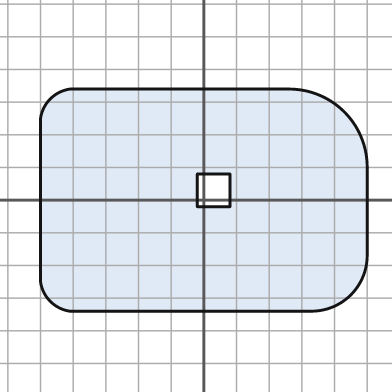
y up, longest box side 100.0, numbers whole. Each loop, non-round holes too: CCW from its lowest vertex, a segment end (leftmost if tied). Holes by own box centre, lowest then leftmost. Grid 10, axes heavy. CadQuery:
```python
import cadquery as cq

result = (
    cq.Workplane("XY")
    .moveTo(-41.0, -34.0)
    .lineTo(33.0, -34.0)
    .threePointArc((45.0, -29.0), (50.0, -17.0))
    .lineTo(50.0, 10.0)
    .threePointArc((43.0, 27.0), (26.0, 34.0))
    .lineTo(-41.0, 34.0)
    .threePointArc((-47.0, 31.0), (-50.0, 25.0))
    .lineTo(-50.0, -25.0)
    .threePointArc((-47.0, -31.0), (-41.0, -34.0))
    .close()
    .moveTo(-2.0, -2.0)
    .lineTo(8.0, -2.0)
    .lineTo(8.0, 8.0)
    .lineTo(-2.0, 8.0)
    .close()
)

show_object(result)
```